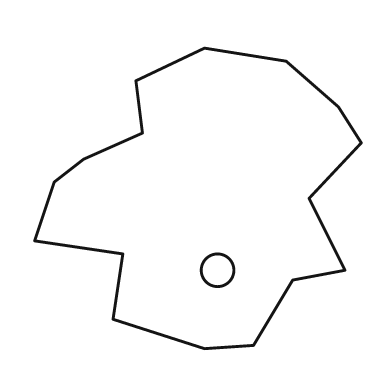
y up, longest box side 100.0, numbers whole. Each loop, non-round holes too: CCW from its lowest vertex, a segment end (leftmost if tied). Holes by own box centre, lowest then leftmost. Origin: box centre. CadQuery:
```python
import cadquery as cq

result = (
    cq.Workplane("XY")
    .moveTo(2.0, -46.0)
    .lineTo(17.0, -45.0)
    .lineTo(29.0, -25.0)
    .lineTo(45.0, -22.0)
    .lineTo(34.0, 0.0)
    .lineTo(50.0, 17.0)
    .lineTo(43.0, 28.0)
    .lineTo(27.0, 42.0)
    .lineTo(2.0, 46.0)
    .lineTo(-19.0, 36.0)
    .lineTo(-17.0, 20.0)
    .lineTo(-35.0, 12.0)
    .lineTo(-44.0, 5.0)
    .lineTo(-50.0, -13.0)
    .lineTo(-23.0, -17.0)
    .lineTo(-26.0, -37.0)
    .close()
    .moveTo(6.0, -22.0)
    .circle(5.0)
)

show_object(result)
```